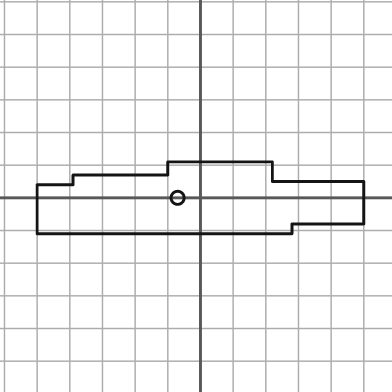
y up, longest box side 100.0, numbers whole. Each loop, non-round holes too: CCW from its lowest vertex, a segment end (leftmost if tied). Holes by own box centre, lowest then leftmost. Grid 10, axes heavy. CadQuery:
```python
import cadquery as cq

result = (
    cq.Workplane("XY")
    .moveTo(-50.0, -11.0)
    .lineTo(28.0, -11.0)
    .lineTo(28.0, -8.0)
    .lineTo(50.0, -8.0)
    .lineTo(50.0, 5.0)
    .lineTo(22.0, 5.0)
    .lineTo(22.0, 11.0)
    .lineTo(-10.0, 11.0)
    .lineTo(-10.0, 7.0)
    .lineTo(-39.0, 7.0)
    .lineTo(-39.0, 4.0)
    .lineTo(-50.0, 4.0)
    .close()
    .moveTo(-7.0, 0.0)
    .circle(2.0)
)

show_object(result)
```